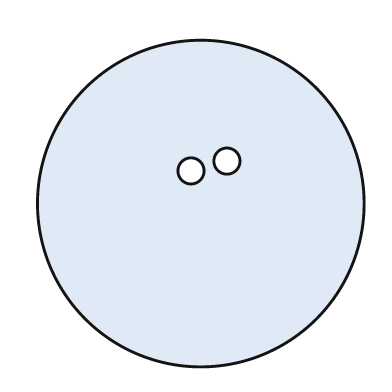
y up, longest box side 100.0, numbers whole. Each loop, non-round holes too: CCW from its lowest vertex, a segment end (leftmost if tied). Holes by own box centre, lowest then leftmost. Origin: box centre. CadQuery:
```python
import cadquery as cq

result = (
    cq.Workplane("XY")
    .moveTo(0.0, 0.0)
    .circle(50.0)
    .moveTo(-3.0, 10.0)
    .circle(4.0)
    .moveTo(8.0, 13.0)
    .circle(4.0)
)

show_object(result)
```